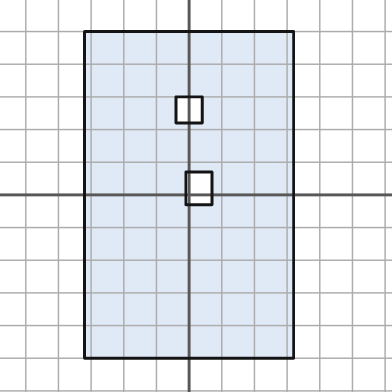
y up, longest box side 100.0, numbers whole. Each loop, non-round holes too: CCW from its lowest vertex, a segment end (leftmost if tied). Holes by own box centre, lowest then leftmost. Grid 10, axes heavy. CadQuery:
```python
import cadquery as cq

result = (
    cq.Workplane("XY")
    .moveTo(-32.0, -50.0)
    .lineTo(32.0, -50.0)
    .lineTo(32.0, 50.0)
    .lineTo(-32.0, 50.0)
    .close()
    .moveTo(-1.0, -3.0)
    .lineTo(7.0, -3.0)
    .lineTo(7.0, 7.0)
    .lineTo(-1.0, 7.0)
    .close()
    .moveTo(-4.0, 22.0)
    .lineTo(4.0, 22.0)
    .lineTo(4.0, 30.0)
    .lineTo(-4.0, 30.0)
    .close()
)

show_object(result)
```